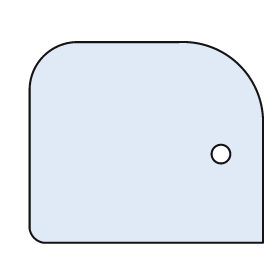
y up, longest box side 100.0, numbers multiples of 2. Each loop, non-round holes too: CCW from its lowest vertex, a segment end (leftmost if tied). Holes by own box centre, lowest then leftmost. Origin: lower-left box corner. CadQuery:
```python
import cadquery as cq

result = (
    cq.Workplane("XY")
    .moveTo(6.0, 0.0)
    .lineTo(100.0, 0.0)
    .lineTo(100.0, 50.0)
    .threePointArc((90.0, 76.0), (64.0, 86.0))
    .lineTo(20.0, 86.0)
    .threePointArc((6.0, 80.0), (0.0, 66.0))
    .lineTo(0.0, 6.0)
    .threePointArc((2.0, 2.0), (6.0, 0.0))
    .close()
    .moveTo(82.0, 38.0)
    .circle(4.0)
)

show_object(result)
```